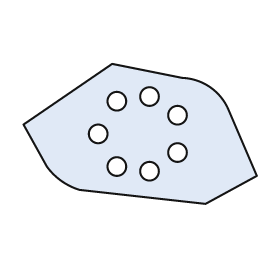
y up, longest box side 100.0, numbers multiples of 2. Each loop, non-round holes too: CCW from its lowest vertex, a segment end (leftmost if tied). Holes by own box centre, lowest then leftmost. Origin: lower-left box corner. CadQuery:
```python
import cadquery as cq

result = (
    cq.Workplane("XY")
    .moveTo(78.0, 0.0)
    .lineTo(100.0, 12.0)
    .lineTo(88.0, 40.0)
    .threePointArc((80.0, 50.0), (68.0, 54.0))
    .lineTo(38.0, 60.0)
    .lineTo(0.0, 34.0)
    .lineTo(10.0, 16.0)
    .threePointArc((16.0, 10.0), (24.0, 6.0))
    .close()
    .moveTo(54.0, 14.0)
    .circle(4.0)
    .moveTo(40.0, 16.0)
    .circle(4.0)
    .moveTo(66.0, 22.0)
    .circle(4.0)
    .moveTo(32.0, 30.0)
    .circle(4.0)
    .moveTo(66.0, 38.0)
    .circle(4.0)
    .moveTo(40.0, 44.0)
    .circle(4.0)
    .moveTo(54.0, 46.0)
    .circle(4.0)
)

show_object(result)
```